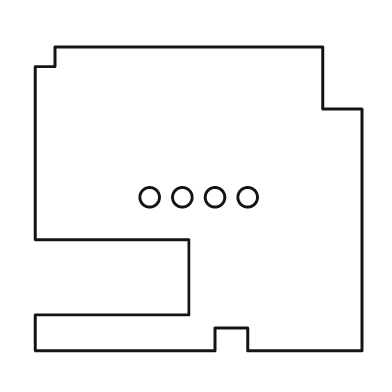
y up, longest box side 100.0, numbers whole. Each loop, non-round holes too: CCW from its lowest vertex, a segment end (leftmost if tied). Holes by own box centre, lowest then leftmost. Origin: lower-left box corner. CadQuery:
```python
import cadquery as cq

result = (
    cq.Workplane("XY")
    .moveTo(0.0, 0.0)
    .lineTo(55.0, 0.0)
    .lineTo(55.0, 7.0)
    .lineTo(65.0, 7.0)
    .lineTo(65.0, 0.0)
    .lineTo(100.0, 0.0)
    .lineTo(100.0, 74.0)
    .lineTo(88.0, 74.0)
    .lineTo(88.0, 93.0)
    .lineTo(6.0, 93.0)
    .lineTo(6.0, 87.0)
    .lineTo(0.0, 87.0)
    .lineTo(0.0, 34.0)
    .lineTo(47.0, 34.0)
    .lineTo(47.0, 11.0)
    .lineTo(0.0, 11.0)
    .close()
    .moveTo(35.0, 47.0)
    .circle(3.0)
    .moveTo(45.0, 47.0)
    .circle(3.0)
    .moveTo(55.0, 47.0)
    .circle(3.0)
    .moveTo(65.0, 47.0)
    .circle(3.0)
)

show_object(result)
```